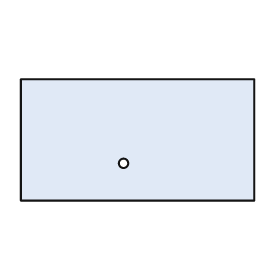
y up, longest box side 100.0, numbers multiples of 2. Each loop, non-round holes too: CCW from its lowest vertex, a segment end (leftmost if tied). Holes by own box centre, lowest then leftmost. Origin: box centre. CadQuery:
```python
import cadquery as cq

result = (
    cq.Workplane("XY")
    .moveTo(-50.0, -26.0)
    .lineTo(50.0, -26.0)
    .lineTo(50.0, 26.0)
    .lineTo(-50.0, 26.0)
    .close()
    .moveTo(-6.0, -10.0)
    .circle(2.0)
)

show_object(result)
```